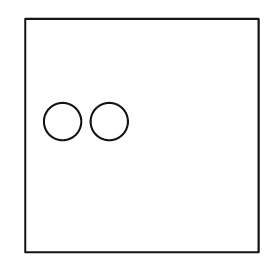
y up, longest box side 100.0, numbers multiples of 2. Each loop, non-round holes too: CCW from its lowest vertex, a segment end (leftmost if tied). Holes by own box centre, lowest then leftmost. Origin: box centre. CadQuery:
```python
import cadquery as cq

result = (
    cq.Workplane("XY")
    .moveTo(-50.0, -50.0)
    .lineTo(50.0, -50.0)
    .lineTo(50.0, 50.0)
    .lineTo(-50.0, 50.0)
    .close()
    .moveTo(-34.0, 6.0)
    .circle(8.0)
    .moveTo(-14.0, 6.0)
    .circle(8.0)
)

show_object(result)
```